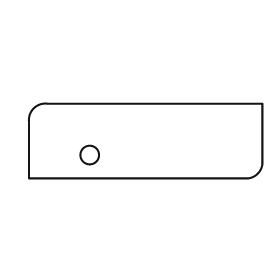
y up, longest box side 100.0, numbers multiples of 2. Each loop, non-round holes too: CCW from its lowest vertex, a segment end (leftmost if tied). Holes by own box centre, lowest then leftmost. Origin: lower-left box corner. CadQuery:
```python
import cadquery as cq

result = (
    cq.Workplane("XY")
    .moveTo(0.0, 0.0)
    .lineTo(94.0, 0.0)
    .threePointArc((98.0, 2.0), (100.0, 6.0))
    .lineTo(100.0, 32.0)
    .lineTo(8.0, 32.0)
    .threePointArc((2.0, 30.0), (0.0, 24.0))
    .close()
    .moveTo(26.0, 10.0)
    .circle(4.0)
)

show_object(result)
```